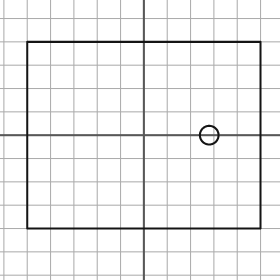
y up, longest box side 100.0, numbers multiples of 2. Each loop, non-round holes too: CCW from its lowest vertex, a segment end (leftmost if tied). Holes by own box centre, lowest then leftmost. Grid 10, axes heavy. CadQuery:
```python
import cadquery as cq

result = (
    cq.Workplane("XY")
    .moveTo(-50.0, -40.0)
    .lineTo(50.0, -40.0)
    .lineTo(50.0, 40.0)
    .lineTo(-50.0, 40.0)
    .close()
    .moveTo(28.0, 0.0)
    .circle(4.0)
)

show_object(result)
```